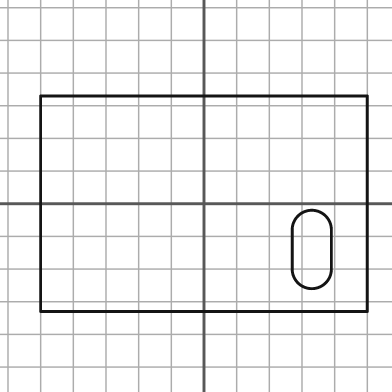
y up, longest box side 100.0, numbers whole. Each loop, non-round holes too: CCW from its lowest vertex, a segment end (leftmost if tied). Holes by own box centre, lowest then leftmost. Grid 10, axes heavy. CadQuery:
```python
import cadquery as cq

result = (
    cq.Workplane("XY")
    .moveTo(-50.0, -33.0)
    .lineTo(50.0, -33.0)
    .lineTo(50.0, 33.0)
    .lineTo(-50.0, 33.0)
    .close()
    .moveTo(27.0, -20.0)
    .threePointArc((33.0, -26.0), (39.0, -20.0))
    .lineTo(39.0, -8.0)
    .threePointArc((33.0, -2.0), (27.0, -8.0))
    .close()
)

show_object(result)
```